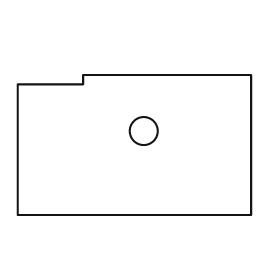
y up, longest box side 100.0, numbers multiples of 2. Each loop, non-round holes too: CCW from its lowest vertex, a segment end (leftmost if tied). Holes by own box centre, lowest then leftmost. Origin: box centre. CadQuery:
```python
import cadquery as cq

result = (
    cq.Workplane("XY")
    .moveTo(-50.0, -30.0)
    .lineTo(50.0, -30.0)
    .lineTo(50.0, 30.0)
    .lineTo(-22.0, 30.0)
    .lineTo(-22.0, 26.0)
    .lineTo(-50.0, 26.0)
    .close()
    .moveTo(4.0, 6.0)
    .circle(6.0)
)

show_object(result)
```